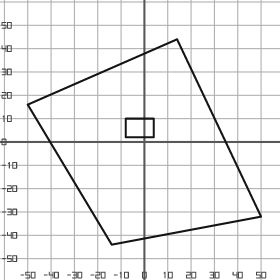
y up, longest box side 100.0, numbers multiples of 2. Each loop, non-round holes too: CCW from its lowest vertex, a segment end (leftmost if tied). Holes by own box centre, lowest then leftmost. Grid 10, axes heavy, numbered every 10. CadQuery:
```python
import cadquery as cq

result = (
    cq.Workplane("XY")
    .moveTo(-14.0, -44.0)
    .lineTo(50.0, -32.0)
    .lineTo(14.0, 44.0)
    .lineTo(-50.0, 16.0)
    .close()
    .moveTo(-8.0, 2.0)
    .lineTo(4.0, 2.0)
    .lineTo(4.0, 10.0)
    .lineTo(-8.0, 10.0)
    .close()
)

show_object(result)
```